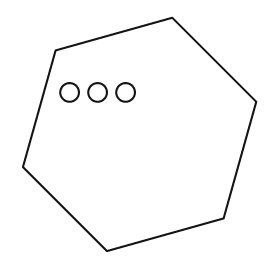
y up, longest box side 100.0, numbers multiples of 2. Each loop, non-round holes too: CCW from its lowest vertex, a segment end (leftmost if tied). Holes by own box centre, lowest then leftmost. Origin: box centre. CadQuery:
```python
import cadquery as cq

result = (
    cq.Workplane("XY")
    .moveTo(-14.0, -50.0)
    .lineTo(36.0, -36.0)
    .lineTo(50.0, 14.0)
    .lineTo(14.0, 50.0)
    .lineTo(-36.0, 36.0)
    .lineTo(-50.0, -14.0)
    .close()
    .moveTo(-30.0, 18.0)
    .circle(4.0)
    .moveTo(-18.0, 18.0)
    .circle(4.0)
    .moveTo(-6.0, 18.0)
    .circle(4.0)
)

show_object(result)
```